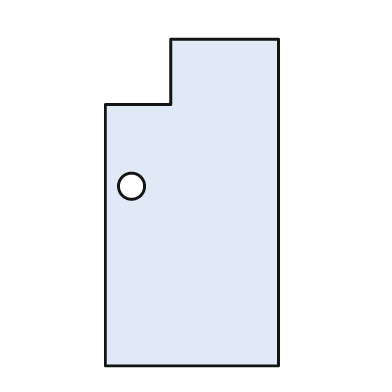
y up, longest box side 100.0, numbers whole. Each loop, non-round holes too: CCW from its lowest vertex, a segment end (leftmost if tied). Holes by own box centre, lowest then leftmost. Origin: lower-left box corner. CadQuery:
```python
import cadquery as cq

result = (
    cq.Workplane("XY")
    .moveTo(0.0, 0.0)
    .lineTo(53.0, 0.0)
    .lineTo(53.0, 100.0)
    .lineTo(20.0, 100.0)
    .lineTo(20.0, 80.0)
    .lineTo(0.0, 80.0)
    .close()
    .moveTo(8.0, 55.0)
    .circle(4.0)
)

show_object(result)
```